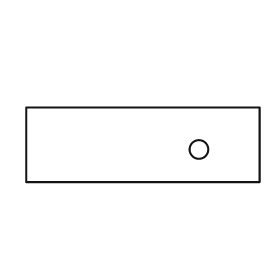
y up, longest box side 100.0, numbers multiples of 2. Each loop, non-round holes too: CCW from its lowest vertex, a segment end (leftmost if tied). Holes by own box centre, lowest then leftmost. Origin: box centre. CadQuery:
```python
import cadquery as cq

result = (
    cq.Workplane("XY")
    .moveTo(-50.0, -16.0)
    .lineTo(50.0, -16.0)
    .lineTo(50.0, 16.0)
    .lineTo(-50.0, 16.0)
    .close()
    .moveTo(24.0, -2.0)
    .circle(4.0)
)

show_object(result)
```